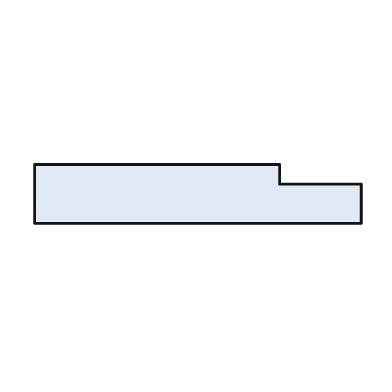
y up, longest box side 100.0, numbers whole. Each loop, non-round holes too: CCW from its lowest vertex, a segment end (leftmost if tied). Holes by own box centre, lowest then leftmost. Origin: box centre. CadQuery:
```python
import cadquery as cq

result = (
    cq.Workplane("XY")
    .moveTo(-50.0, -9.0)
    .lineTo(50.0, -9.0)
    .lineTo(50.0, 3.0)
    .lineTo(25.0, 3.0)
    .lineTo(25.0, 9.0)
    .lineTo(-50.0, 9.0)
    .close()
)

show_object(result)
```